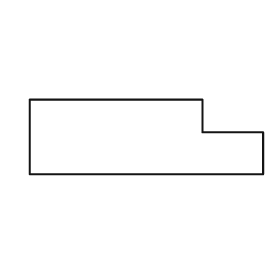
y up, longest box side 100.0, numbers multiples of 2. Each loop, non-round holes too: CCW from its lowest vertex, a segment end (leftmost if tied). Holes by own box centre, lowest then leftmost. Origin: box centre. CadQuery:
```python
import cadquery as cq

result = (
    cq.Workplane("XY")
    .moveTo(-50.0, -16.0)
    .lineTo(50.0, -16.0)
    .lineTo(50.0, 2.0)
    .lineTo(24.0, 2.0)
    .lineTo(24.0, 16.0)
    .lineTo(-50.0, 16.0)
    .close()
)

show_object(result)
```